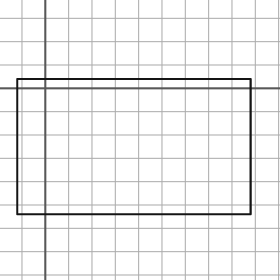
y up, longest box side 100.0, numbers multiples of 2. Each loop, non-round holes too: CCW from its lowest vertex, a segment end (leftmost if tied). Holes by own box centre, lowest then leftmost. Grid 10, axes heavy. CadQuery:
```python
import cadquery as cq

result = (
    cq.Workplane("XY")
    .moveTo(-12.0, -54.0)
    .lineTo(88.0, -54.0)
    .lineTo(88.0, 4.0)
    .lineTo(-12.0, 4.0)
    .close()
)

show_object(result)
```